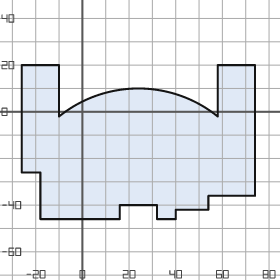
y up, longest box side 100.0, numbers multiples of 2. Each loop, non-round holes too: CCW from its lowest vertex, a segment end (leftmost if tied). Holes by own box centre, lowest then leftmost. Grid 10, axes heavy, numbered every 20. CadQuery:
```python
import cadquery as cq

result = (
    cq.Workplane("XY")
    .moveTo(-18.0, -46.0)
    .lineTo(16.0, -46.0)
    .lineTo(16.0, -40.0)
    .lineTo(32.0, -40.0)
    .lineTo(32.0, -46.0)
    .lineTo(40.0, -46.0)
    .lineTo(40.0, -42.0)
    .lineTo(54.0, -42.0)
    .lineTo(54.0, -36.0)
    .lineTo(74.0, -36.0)
    .lineTo(74.0, 20.0)
    .lineTo(58.0, 20.0)
    .lineTo(58.0, -2.0)
    .threePointArc((24.0, 10.0), (-10.0, -2.0))
    .lineTo(-10.0, 20.0)
    .lineTo(-26.0, 20.0)
    .lineTo(-26.0, -26.0)
    .lineTo(-18.0, -26.0)
    .close()
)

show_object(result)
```